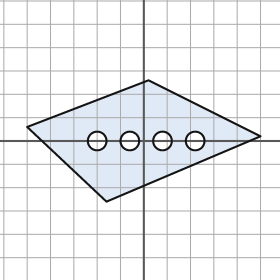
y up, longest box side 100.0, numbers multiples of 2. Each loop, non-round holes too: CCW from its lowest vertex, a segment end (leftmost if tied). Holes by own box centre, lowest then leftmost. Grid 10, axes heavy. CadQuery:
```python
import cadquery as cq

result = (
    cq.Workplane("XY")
    .moveTo(-16.0, -26.0)
    .lineTo(50.0, 2.0)
    .lineTo(2.0, 26.0)
    .lineTo(-50.0, 6.0)
    .close()
    .moveTo(-20.0, 0.0)
    .circle(4.0)
    .moveTo(-6.0, 0.0)
    .circle(4.0)
    .moveTo(8.0, 0.0)
    .circle(4.0)
    .moveTo(22.0, 0.0)
    .circle(4.0)
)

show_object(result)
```